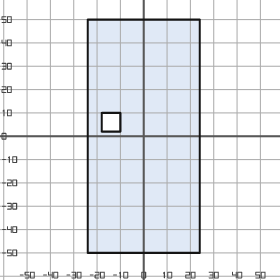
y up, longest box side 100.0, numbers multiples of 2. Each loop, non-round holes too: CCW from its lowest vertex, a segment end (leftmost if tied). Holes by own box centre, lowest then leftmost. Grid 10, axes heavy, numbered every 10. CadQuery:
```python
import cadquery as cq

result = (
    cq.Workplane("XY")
    .moveTo(-24.0, -50.0)
    .lineTo(24.0, -50.0)
    .lineTo(24.0, 50.0)
    .lineTo(-24.0, 50.0)
    .close()
    .moveTo(-18.0, 2.0)
    .lineTo(-10.0, 2.0)
    .lineTo(-10.0, 10.0)
    .lineTo(-18.0, 10.0)
    .close()
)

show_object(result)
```